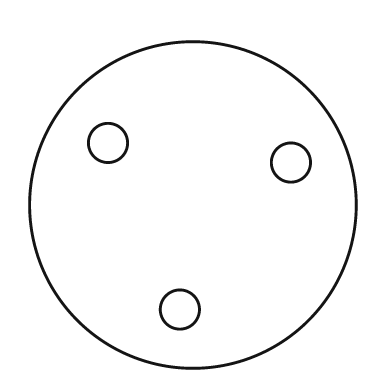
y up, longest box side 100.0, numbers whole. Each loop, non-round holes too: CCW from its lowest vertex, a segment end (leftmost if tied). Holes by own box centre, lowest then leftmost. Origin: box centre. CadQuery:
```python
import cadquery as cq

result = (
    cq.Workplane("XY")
    .moveTo(0.0, 0.0)
    .circle(50.0)
    .moveTo(-4.0, -32.0)
    .circle(6.0)
    .moveTo(30.0, 13.0)
    .circle(6.0)
    .moveTo(-26.0, 19.0)
    .circle(6.0)
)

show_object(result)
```